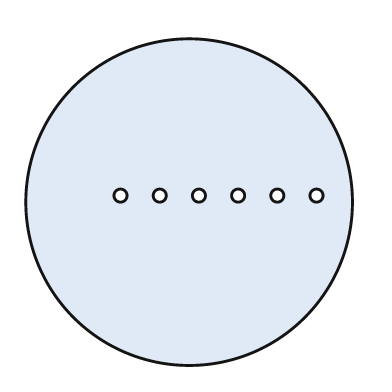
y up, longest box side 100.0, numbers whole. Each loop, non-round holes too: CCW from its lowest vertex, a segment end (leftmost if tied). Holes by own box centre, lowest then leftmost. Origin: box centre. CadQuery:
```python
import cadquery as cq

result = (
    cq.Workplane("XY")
    .moveTo(0.0, 0.0)
    .circle(50.0)
    .moveTo(-21.0, 2.0)
    .circle(2.0)
    .moveTo(-9.0, 2.0)
    .circle(2.0)
    .moveTo(3.0, 2.0)
    .circle(2.0)
    .moveTo(15.0, 2.0)
    .circle(2.0)
    .moveTo(27.0, 2.0)
    .circle(2.0)
    .moveTo(39.0, 2.0)
    .circle(2.0)
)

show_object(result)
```